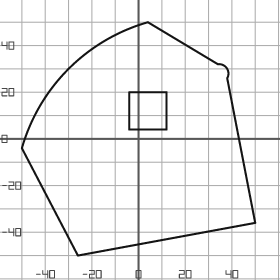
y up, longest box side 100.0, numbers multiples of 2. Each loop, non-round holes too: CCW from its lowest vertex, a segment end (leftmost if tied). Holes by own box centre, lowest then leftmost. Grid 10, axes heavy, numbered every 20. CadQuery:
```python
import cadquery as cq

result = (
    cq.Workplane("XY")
    .moveTo(-26.0, -50.0)
    .lineTo(50.0, -36.0)
    .lineTo(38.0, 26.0)
    .threePointArc((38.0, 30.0), (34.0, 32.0))
    .lineTo(4.0, 50.0)
    .threePointArc((-30.0, 30.0), (-50.0, -4.0))
    .close()
    .moveTo(-4.0, 4.0)
    .lineTo(12.0, 4.0)
    .lineTo(12.0, 20.0)
    .lineTo(-4.0, 20.0)
    .close()
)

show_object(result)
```